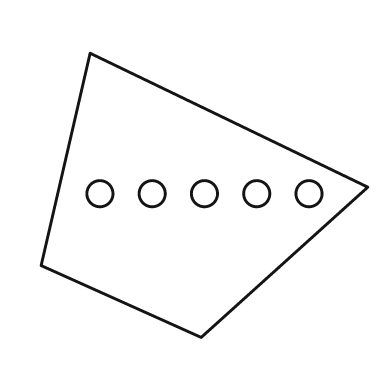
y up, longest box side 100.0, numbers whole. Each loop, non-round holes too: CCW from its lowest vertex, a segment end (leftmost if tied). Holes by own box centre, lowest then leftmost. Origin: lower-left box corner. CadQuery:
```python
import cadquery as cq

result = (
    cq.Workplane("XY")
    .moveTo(49.0, 0.0)
    .lineTo(100.0, 46.0)
    .lineTo(15.0, 87.0)
    .lineTo(0.0, 22.0)
    .close()
    .moveTo(18.0, 44.0)
    .circle(4.0)
    .moveTo(34.0, 44.0)
    .circle(4.0)
    .moveTo(50.0, 44.0)
    .circle(4.0)
    .moveTo(66.0, 44.0)
    .circle(4.0)
    .moveTo(82.0, 44.0)
    .circle(4.0)
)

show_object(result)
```